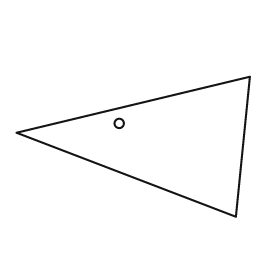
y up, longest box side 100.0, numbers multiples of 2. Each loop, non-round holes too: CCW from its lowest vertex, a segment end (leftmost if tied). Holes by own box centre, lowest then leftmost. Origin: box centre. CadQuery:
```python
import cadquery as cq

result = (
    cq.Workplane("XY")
    .moveTo(44.0, -30.0)
    .lineTo(50.0, 30.0)
    .lineTo(-50.0, 6.0)
    .close()
    .moveTo(-6.0, 10.0)
    .circle(2.0)
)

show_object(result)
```